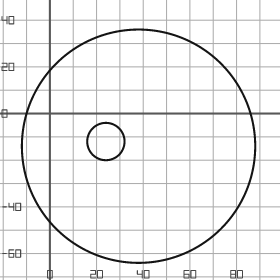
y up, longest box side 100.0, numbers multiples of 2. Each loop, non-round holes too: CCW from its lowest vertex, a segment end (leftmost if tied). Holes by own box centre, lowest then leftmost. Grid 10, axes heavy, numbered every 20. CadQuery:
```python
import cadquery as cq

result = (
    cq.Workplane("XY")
    .moveTo(38.0, -14.0)
    .circle(50.0)
    .moveTo(24.0, -12.0)
    .circle(8.0)
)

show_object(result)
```